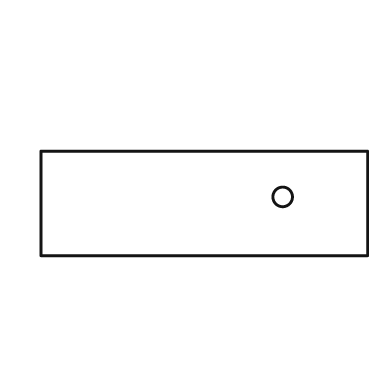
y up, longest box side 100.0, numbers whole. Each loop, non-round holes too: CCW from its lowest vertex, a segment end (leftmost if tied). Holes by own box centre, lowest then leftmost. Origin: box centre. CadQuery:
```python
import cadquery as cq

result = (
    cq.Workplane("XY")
    .moveTo(-50.0, -16.0)
    .lineTo(50.0, -16.0)
    .lineTo(50.0, 16.0)
    .lineTo(-50.0, 16.0)
    .close()
    .moveTo(24.0, 2.0)
    .circle(3.0)
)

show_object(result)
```